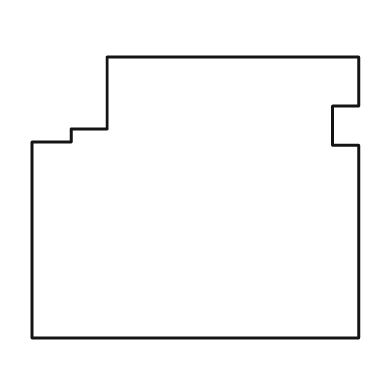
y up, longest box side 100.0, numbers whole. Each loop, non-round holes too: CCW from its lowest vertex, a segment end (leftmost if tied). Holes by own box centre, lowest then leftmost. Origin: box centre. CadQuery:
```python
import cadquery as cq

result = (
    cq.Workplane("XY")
    .moveTo(-50.0, -43.0)
    .lineTo(50.0, -43.0)
    .lineTo(50.0, 16.0)
    .lineTo(42.0, 16.0)
    .lineTo(42.0, 28.0)
    .lineTo(50.0, 28.0)
    .lineTo(50.0, 43.0)
    .lineTo(-27.0, 43.0)
    .lineTo(-27.0, 21.0)
    .lineTo(-38.0, 21.0)
    .lineTo(-38.0, 17.0)
    .lineTo(-50.0, 17.0)
    .close()
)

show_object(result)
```